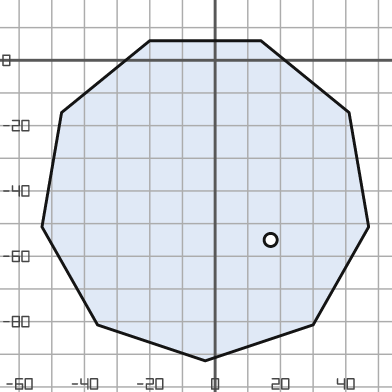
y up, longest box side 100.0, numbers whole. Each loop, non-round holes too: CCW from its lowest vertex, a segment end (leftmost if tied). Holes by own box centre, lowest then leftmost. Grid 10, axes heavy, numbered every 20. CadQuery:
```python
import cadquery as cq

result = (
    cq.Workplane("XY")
    .moveTo(-3.0, -92.0)
    .lineTo(30.0, -81.0)
    .lineTo(47.0, -51.0)
    .lineTo(41.0, -16.0)
    .lineTo(14.0, 6.0)
    .lineTo(-20.0, 6.0)
    .lineTo(-47.0, -16.0)
    .lineTo(-53.0, -51.0)
    .lineTo(-36.0, -81.0)
    .close()
    .moveTo(17.0, -55.0)
    .circle(2.0)
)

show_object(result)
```